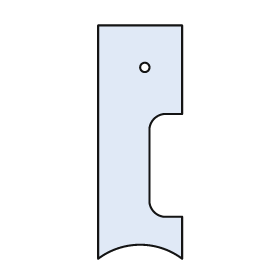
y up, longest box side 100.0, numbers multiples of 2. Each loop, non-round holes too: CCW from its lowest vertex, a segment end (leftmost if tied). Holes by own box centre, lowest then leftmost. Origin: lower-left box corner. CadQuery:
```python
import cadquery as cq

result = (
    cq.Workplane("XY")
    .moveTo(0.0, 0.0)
    .threePointArc((18.0, 6.0), (36.0, 0.0))
    .lineTo(36.0, 18.0)
    .lineTo(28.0, 18.0)
    .threePointArc((24.0, 20.0), (22.0, 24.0))
    .lineTo(22.0, 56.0)
    .threePointArc((24.0, 60.0), (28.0, 62.0))
    .lineTo(36.0, 62.0)
    .lineTo(36.0, 100.0)
    .lineTo(0.0, 100.0)
    .close()
    .moveTo(20.0, 82.0)
    .circle(2.0)
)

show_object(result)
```